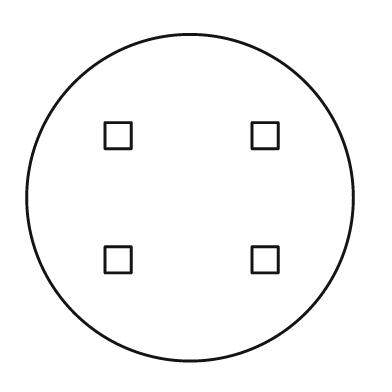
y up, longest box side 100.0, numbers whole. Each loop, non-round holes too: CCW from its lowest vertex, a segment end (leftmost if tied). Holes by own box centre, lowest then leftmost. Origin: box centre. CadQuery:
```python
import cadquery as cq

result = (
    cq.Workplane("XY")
    .moveTo(0.0, 0.0)
    .circle(50.0)
    .moveTo(-26.0, -23.0)
    .lineTo(-18.0, -23.0)
    .lineTo(-18.0, -15.0)
    .lineTo(-26.0, -15.0)
    .close()
    .moveTo(19.0, -23.0)
    .lineTo(27.0, -23.0)
    .lineTo(27.0, -15.0)
    .lineTo(19.0, -15.0)
    .close()
    .moveTo(-26.0, 15.0)
    .lineTo(-18.0, 15.0)
    .lineTo(-18.0, 23.0)
    .lineTo(-26.0, 23.0)
    .close()
    .moveTo(19.0, 15.0)
    .lineTo(27.0, 15.0)
    .lineTo(27.0, 23.0)
    .lineTo(19.0, 23.0)
    .close()
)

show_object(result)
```